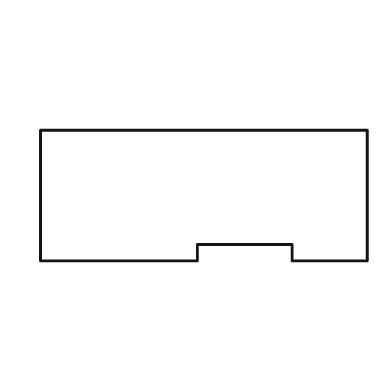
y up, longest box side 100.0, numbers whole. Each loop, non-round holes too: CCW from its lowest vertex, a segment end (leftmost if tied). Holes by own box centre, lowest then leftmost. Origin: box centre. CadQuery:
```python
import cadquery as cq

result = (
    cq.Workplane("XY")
    .moveTo(-50.0, -20.0)
    .lineTo(-2.0, -20.0)
    .lineTo(-2.0, -15.0)
    .lineTo(27.0, -15.0)
    .lineTo(27.0, -20.0)
    .lineTo(50.0, -20.0)
    .lineTo(50.0, 20.0)
    .lineTo(-50.0, 20.0)
    .close()
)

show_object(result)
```